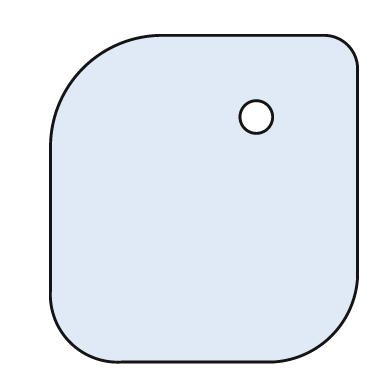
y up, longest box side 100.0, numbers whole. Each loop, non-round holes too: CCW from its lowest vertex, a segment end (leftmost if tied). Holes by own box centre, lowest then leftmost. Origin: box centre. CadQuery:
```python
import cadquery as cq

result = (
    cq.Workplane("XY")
    .moveTo(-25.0, -50.0)
    .lineTo(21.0, -50.0)
    .threePointArc((39.0, -42.0), (47.0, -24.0))
    .lineTo(47.0, 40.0)
    .threePointArc((44.0, 47.0), (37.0, 50.0))
    .lineTo(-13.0, 50.0)
    .threePointArc((-37.0, 40.0), (-47.0, 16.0))
    .lineTo(-47.0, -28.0)
    .threePointArc((-41.0, -44.0), (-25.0, -50.0))
    .close()
    .moveTo(16.0, 25.0)
    .circle(5.0)
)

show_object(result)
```